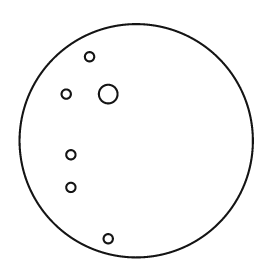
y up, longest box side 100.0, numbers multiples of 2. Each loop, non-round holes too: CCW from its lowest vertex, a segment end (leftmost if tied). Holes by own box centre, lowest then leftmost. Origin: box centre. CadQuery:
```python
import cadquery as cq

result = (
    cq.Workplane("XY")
    .moveTo(0.0, 0.0)
    .circle(50.0)
    .moveTo(-12.0, -42.0)
    .circle(2.0)
    .moveTo(-28.0, -20.0)
    .circle(2.0)
    .moveTo(-28.0, -6.0)
    .circle(2.0)
    .moveTo(-30.0, 20.0)
    .circle(2.0)
    .moveTo(-12.0, 20.0)
    .circle(4.0)
    .moveTo(-20.0, 36.0)
    .circle(2.0)
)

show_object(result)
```